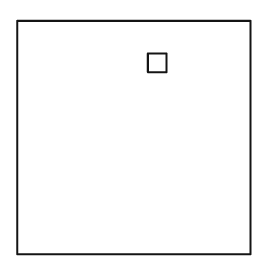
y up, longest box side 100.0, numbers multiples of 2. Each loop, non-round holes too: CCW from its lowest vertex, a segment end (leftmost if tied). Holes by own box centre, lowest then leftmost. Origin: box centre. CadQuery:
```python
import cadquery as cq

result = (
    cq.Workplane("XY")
    .moveTo(-50.0, -50.0)
    .lineTo(50.0, -50.0)
    .lineTo(50.0, 50.0)
    .lineTo(-50.0, 50.0)
    .close()
    .moveTo(6.0, 28.0)
    .lineTo(14.0, 28.0)
    .lineTo(14.0, 36.0)
    .lineTo(6.0, 36.0)
    .close()
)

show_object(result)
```